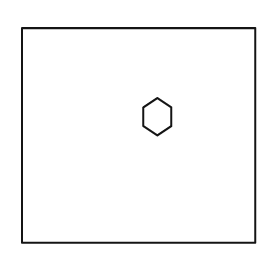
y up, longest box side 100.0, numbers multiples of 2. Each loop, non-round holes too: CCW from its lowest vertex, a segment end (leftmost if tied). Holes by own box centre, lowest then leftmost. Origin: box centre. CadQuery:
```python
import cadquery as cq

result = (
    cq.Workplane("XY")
    .moveTo(-50.0, -46.0)
    .lineTo(50.0, -46.0)
    .lineTo(50.0, 46.0)
    .lineTo(-50.0, 46.0)
    .close()
    .moveTo(8.0, 0.0)
    .lineTo(14.0, 4.0)
    .lineTo(14.0, 12.0)
    .lineTo(8.0, 16.0)
    .lineTo(2.0, 12.0)
    .lineTo(2.0, 4.0)
    .close()
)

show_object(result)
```